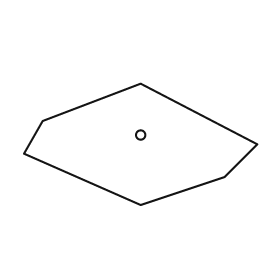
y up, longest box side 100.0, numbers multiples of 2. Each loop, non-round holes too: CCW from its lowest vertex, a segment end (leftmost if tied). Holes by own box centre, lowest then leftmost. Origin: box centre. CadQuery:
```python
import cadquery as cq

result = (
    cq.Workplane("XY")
    .moveTo(0.0, -26.0)
    .lineTo(36.0, -14.0)
    .lineTo(50.0, 0.0)
    .lineTo(0.0, 26.0)
    .lineTo(-42.0, 10.0)
    .lineTo(-50.0, -4.0)
    .close()
    .moveTo(0.0, 4.0)
    .circle(2.0)
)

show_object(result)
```